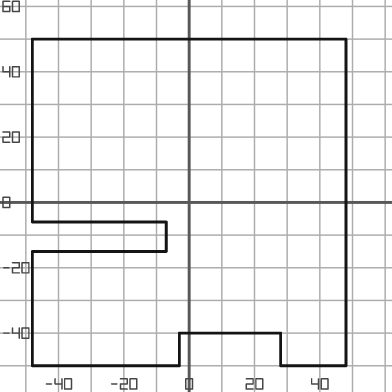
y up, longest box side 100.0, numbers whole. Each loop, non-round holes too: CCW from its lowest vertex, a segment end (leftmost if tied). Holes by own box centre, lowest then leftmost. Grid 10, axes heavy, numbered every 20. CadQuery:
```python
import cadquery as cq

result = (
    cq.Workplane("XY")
    .moveTo(-48.0, -50.0)
    .lineTo(-3.0, -50.0)
    .lineTo(-3.0, -40.0)
    .lineTo(28.0, -40.0)
    .lineTo(28.0, -50.0)
    .lineTo(48.0, -50.0)
    .lineTo(48.0, 50.0)
    .lineTo(-48.0, 50.0)
    .lineTo(-48.0, -6.0)
    .lineTo(-7.0, -6.0)
    .lineTo(-7.0, -15.0)
    .lineTo(-48.0, -15.0)
    .close()
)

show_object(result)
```